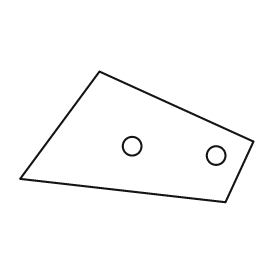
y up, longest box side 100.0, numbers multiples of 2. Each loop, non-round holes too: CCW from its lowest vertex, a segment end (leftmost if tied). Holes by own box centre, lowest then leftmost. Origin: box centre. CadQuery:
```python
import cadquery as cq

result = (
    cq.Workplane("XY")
    .moveTo(38.0, -28.0)
    .lineTo(50.0, -2.0)
    .lineTo(-16.0, 28.0)
    .lineTo(-50.0, -18.0)
    .close()
    .moveTo(34.0, -8.0)
    .circle(4.0)
    .moveTo(-2.0, -4.0)
    .circle(4.0)
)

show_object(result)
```